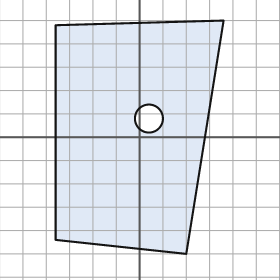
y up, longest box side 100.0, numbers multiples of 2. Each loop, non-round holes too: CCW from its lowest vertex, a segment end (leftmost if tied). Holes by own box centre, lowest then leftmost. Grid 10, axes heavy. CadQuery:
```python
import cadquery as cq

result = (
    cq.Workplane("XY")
    .moveTo(20.0, -50.0)
    .lineTo(36.0, 50.0)
    .lineTo(-36.0, 48.0)
    .lineTo(-36.0, -44.0)
    .close()
    .moveTo(4.0, 8.0)
    .circle(6.0)
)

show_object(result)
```